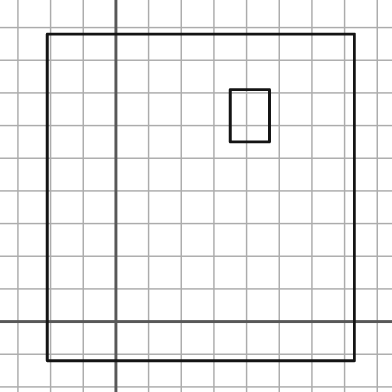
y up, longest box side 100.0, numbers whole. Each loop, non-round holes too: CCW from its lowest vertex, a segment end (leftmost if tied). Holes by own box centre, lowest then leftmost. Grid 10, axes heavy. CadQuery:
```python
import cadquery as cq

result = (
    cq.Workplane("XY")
    .moveTo(-21.0, -12.0)
    .lineTo(73.0, -12.0)
    .lineTo(73.0, 88.0)
    .lineTo(-21.0, 88.0)
    .close()
    .moveTo(35.0, 55.0)
    .lineTo(47.0, 55.0)
    .lineTo(47.0, 71.0)
    .lineTo(35.0, 71.0)
    .close()
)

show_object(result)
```